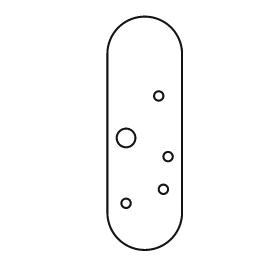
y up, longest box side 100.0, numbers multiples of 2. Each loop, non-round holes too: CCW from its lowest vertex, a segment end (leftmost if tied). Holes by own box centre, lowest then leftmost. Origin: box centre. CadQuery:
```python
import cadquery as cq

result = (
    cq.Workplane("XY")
    .moveTo(-16.0, -34.0)
    .threePointArc((0.0, -50.0), (16.0, -34.0))
    .lineTo(16.0, 34.0)
    .threePointArc((0.0, 50.0), (-16.0, 34.0))
    .close()
    .moveTo(-8.0, -30.0)
    .circle(2.0)
    .moveTo(8.0, -24.0)
    .circle(2.0)
    .moveTo(10.0, -10.0)
    .circle(2.0)
    .moveTo(-8.0, -2.0)
    .circle(4.0)
    .moveTo(6.0, 16.0)
    .circle(2.0)
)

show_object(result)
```